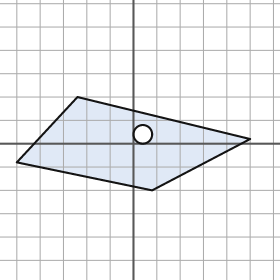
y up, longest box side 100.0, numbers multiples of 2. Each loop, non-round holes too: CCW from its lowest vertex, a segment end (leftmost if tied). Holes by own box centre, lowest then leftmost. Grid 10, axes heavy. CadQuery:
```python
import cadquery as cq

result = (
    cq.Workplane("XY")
    .moveTo(8.0, -20.0)
    .lineTo(50.0, 2.0)
    .lineTo(-24.0, 20.0)
    .lineTo(-50.0, -8.0)
    .close()
    .moveTo(4.0, 4.0)
    .circle(4.0)
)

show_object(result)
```